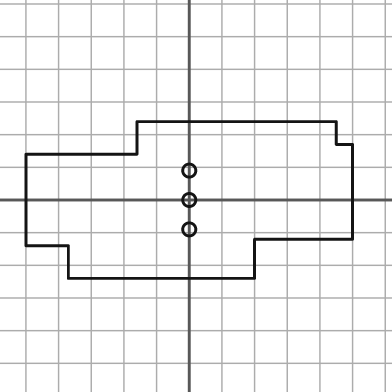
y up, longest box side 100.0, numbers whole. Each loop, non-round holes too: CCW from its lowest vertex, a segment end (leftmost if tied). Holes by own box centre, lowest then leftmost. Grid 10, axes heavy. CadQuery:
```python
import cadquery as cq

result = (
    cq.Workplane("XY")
    .moveTo(-37.0, -24.0)
    .lineTo(20.0, -24.0)
    .lineTo(20.0, -12.0)
    .lineTo(50.0, -12.0)
    .lineTo(50.0, 17.0)
    .lineTo(45.0, 17.0)
    .lineTo(45.0, 24.0)
    .lineTo(-16.0, 24.0)
    .lineTo(-16.0, 14.0)
    .lineTo(-50.0, 14.0)
    .lineTo(-50.0, -14.0)
    .lineTo(-37.0, -14.0)
    .close()
    .moveTo(0.0, -9.0)
    .circle(2.0)
    .moveTo(0.0, 0.0)
    .circle(2.0)
    .moveTo(0.0, 9.0)
    .circle(2.0)
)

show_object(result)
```